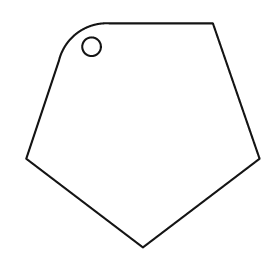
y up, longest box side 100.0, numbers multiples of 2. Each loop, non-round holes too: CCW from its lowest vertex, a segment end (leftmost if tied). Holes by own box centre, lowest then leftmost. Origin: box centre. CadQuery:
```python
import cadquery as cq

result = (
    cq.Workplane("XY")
    .moveTo(0.0, -48.0)
    .lineTo(50.0, -10.0)
    .lineTo(30.0, 48.0)
    .lineTo(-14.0, 48.0)
    .threePointArc((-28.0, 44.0), (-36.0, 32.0))
    .lineTo(-50.0, -10.0)
    .close()
    .moveTo(-22.0, 38.0)
    .circle(4.0)
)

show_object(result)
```